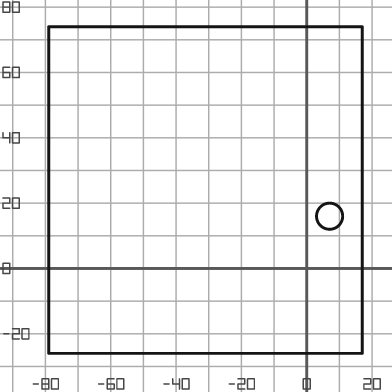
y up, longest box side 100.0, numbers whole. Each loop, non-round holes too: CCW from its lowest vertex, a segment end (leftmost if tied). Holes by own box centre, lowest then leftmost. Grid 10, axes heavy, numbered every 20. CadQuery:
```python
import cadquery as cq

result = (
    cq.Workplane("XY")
    .moveTo(-79.0, -26.0)
    .lineTo(17.0, -26.0)
    .lineTo(17.0, 74.0)
    .lineTo(-79.0, 74.0)
    .close()
    .moveTo(7.0, 16.0)
    .circle(4.0)
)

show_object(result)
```